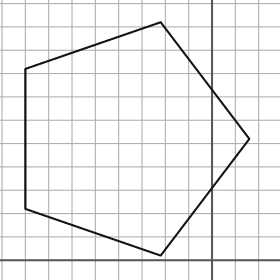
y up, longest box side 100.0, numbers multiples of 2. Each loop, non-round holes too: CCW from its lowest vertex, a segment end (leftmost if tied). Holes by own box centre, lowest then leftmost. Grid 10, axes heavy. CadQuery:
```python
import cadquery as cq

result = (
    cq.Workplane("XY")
    .moveTo(-22.0, 2.0)
    .lineTo(16.0, 52.0)
    .lineTo(-22.0, 102.0)
    .lineTo(-80.0, 82.0)
    .lineTo(-80.0, 22.0)
    .close()
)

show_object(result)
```